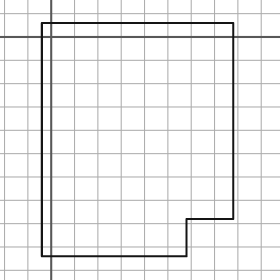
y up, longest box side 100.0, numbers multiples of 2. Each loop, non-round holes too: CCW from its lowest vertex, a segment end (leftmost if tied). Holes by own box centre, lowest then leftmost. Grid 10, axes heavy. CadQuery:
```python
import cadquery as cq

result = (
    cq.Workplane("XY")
    .moveTo(-4.0, -94.0)
    .lineTo(58.0, -94.0)
    .lineTo(58.0, -78.0)
    .lineTo(78.0, -78.0)
    .lineTo(78.0, 6.0)
    .lineTo(-4.0, 6.0)
    .close()
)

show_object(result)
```